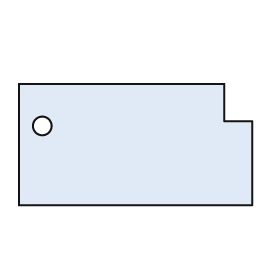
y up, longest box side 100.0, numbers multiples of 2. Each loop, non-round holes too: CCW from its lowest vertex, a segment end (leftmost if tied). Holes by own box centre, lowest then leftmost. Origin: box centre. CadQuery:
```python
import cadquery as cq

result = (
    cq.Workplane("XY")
    .moveTo(-50.0, -26.0)
    .lineTo(50.0, -26.0)
    .lineTo(50.0, 10.0)
    .lineTo(38.0, 10.0)
    .lineTo(38.0, 26.0)
    .lineTo(-50.0, 26.0)
    .close()
    .moveTo(-40.0, 8.0)
    .circle(4.0)
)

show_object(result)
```